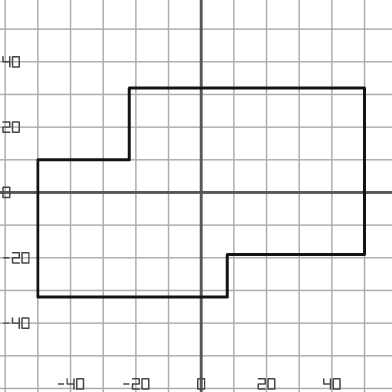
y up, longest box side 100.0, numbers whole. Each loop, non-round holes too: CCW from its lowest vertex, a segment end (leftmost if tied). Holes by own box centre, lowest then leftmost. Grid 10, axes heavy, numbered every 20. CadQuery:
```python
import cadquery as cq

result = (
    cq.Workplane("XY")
    .moveTo(-50.0, -32.0)
    .lineTo(8.0, -32.0)
    .lineTo(8.0, -19.0)
    .lineTo(50.0, -19.0)
    .lineTo(50.0, 32.0)
    .lineTo(-22.0, 32.0)
    .lineTo(-22.0, 10.0)
    .lineTo(-50.0, 10.0)
    .close()
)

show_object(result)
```